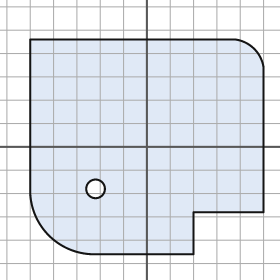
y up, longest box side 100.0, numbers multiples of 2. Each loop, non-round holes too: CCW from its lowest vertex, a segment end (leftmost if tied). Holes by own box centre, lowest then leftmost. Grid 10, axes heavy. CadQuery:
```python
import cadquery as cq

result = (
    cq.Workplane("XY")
    .moveTo(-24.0, -46.0)
    .lineTo(20.0, -46.0)
    .lineTo(20.0, -28.0)
    .lineTo(50.0, -28.0)
    .lineTo(50.0, 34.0)
    .threePointArc((46.0, 42.0), (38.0, 46.0))
    .lineTo(-50.0, 46.0)
    .lineTo(-50.0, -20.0)
    .threePointArc((-42.0, -38.0), (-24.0, -46.0))
    .close()
    .moveTo(-22.0, -18.0)
    .circle(4.0)
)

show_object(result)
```